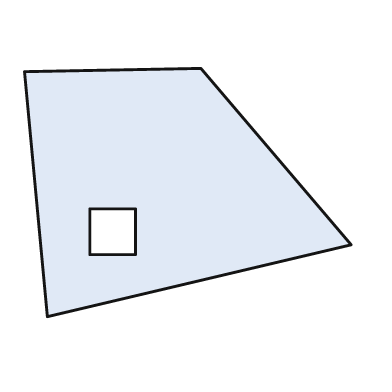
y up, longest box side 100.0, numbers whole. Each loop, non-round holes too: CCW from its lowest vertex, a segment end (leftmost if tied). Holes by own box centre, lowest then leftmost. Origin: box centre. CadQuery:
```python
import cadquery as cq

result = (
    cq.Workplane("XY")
    .moveTo(-43.0, -38.0)
    .lineTo(50.0, -16.0)
    .lineTo(4.0, 38.0)
    .lineTo(-50.0, 37.0)
    .close()
    .moveTo(-30.0, -19.0)
    .lineTo(-16.0, -19.0)
    .lineTo(-16.0, -5.0)
    .lineTo(-30.0, -5.0)
    .close()
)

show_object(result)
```